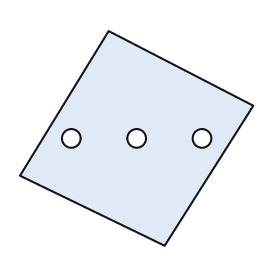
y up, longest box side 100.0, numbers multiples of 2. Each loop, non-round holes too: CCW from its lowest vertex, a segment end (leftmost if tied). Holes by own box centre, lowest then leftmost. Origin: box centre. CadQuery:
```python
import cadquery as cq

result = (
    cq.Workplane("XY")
    .moveTo(12.0, -46.0)
    .lineTo(50.0, 14.0)
    .lineTo(-12.0, 46.0)
    .lineTo(-50.0, -16.0)
    .close()
    .moveTo(-28.0, 0.0)
    .circle(4.0)
    .moveTo(0.0, 0.0)
    .circle(4.0)
    .moveTo(28.0, 0.0)
    .circle(4.0)
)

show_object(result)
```